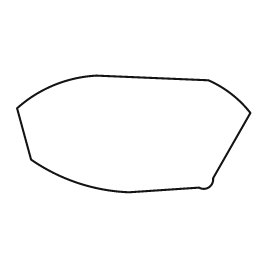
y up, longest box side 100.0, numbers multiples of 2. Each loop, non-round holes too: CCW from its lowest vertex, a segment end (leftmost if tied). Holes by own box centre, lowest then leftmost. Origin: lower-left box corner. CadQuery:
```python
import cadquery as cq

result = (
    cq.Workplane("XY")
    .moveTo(48.0, 0.0)
    .lineTo(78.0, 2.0)
    .threePointArc((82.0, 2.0), (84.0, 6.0))
    .lineTo(100.0, 34.0)
    .threePointArc((92.0, 42.0), (82.0, 48.0))
    .lineTo(34.0, 50.0)
    .threePointArc((16.0, 46.0), (0.0, 36.0))
    .lineTo(6.0, 14.0)
    .threePointArc((26.0, 4.0), (48.0, 0.0))
    .close()
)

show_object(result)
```